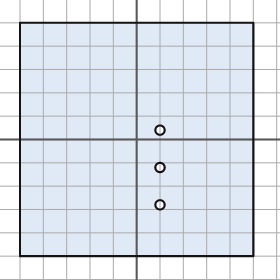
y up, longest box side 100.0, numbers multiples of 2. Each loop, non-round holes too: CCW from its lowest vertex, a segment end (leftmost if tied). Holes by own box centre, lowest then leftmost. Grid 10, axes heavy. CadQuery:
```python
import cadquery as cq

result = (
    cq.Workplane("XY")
    .moveTo(-50.0, -50.0)
    .lineTo(50.0, -50.0)
    .lineTo(50.0, 50.0)
    .lineTo(-50.0, 50.0)
    .close()
    .moveTo(10.0, -28.0)
    .circle(2.0)
    .moveTo(10.0, -12.0)
    .circle(2.0)
    .moveTo(10.0, 4.0)
    .circle(2.0)
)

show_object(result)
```